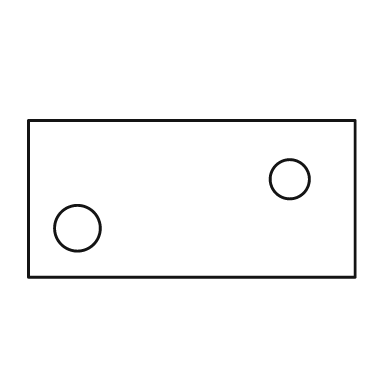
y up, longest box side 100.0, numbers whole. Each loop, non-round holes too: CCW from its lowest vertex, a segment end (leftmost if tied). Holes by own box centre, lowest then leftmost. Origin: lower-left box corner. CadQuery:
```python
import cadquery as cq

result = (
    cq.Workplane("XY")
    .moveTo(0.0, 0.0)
    .lineTo(100.0, 0.0)
    .lineTo(100.0, 48.0)
    .lineTo(0.0, 48.0)
    .close()
    .moveTo(15.0, 15.0)
    .circle(7.0)
    .moveTo(80.0, 30.0)
    .circle(6.0)
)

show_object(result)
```